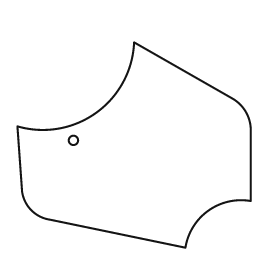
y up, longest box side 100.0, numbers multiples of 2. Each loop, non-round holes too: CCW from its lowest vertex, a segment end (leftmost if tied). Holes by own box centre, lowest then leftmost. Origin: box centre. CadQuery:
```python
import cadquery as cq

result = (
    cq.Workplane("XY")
    .moveTo(22.0, -44.0)
    .threePointArc((32.0, -28.0), (50.0, -24.0))
    .lineTo(50.0, 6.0)
    .threePointArc((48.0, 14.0), (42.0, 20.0))
    .lineTo(0.0, 44.0)
    .threePointArc((-16.0, 14.0), (-50.0, 8.0))
    .lineTo(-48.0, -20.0)
    .threePointArc((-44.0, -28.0), (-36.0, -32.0))
    .close()
    .moveTo(-26.0, 2.0)
    .circle(2.0)
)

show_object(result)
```